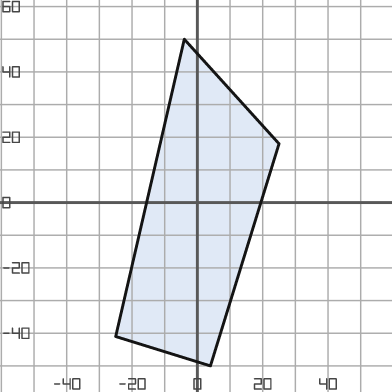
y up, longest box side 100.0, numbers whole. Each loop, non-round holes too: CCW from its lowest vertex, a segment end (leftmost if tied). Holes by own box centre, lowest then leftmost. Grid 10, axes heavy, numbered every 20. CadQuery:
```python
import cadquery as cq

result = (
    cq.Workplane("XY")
    .moveTo(4.0, -50.0)
    .lineTo(25.0, 18.0)
    .lineTo(-4.0, 50.0)
    .lineTo(-25.0, -41.0)
    .close()
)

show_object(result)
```